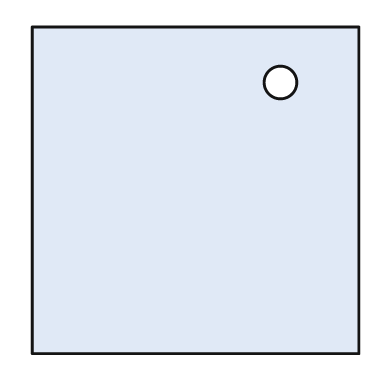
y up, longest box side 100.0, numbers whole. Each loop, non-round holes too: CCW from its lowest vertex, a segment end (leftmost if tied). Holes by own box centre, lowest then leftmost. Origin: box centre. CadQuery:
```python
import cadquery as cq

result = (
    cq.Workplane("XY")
    .moveTo(-50.0, -50.0)
    .lineTo(50.0, -50.0)
    .lineTo(50.0, 50.0)
    .lineTo(-50.0, 50.0)
    .close()
    .moveTo(26.0, 33.0)
    .circle(5.0)
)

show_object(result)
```